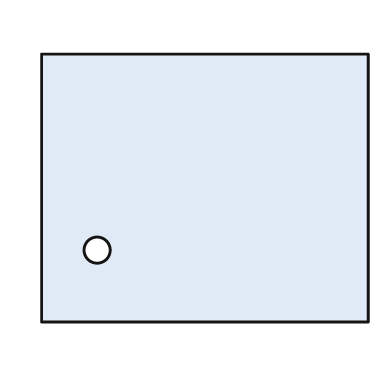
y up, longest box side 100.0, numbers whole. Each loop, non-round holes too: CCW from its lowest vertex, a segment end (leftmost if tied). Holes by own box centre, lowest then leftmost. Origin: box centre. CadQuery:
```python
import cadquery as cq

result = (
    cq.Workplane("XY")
    .moveTo(-50.0, -41.0)
    .lineTo(50.0, -41.0)
    .lineTo(50.0, 41.0)
    .lineTo(-50.0, 41.0)
    .close()
    .moveTo(-33.0, -19.0)
    .circle(4.0)
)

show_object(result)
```